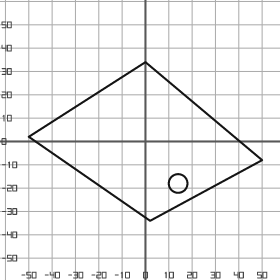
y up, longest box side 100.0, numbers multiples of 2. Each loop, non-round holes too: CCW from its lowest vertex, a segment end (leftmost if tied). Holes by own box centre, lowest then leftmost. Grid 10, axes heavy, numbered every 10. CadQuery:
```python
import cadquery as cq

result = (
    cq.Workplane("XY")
    .moveTo(2.0, -34.0)
    .lineTo(50.0, -8.0)
    .lineTo(0.0, 34.0)
    .lineTo(-50.0, 2.0)
    .close()
    .moveTo(14.0, -18.0)
    .circle(4.0)
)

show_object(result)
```